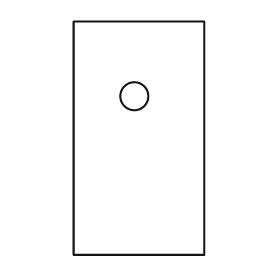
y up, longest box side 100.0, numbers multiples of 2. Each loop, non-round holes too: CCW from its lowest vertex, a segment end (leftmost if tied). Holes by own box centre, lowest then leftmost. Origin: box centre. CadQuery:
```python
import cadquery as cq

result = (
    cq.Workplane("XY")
    .moveTo(-28.0, -50.0)
    .lineTo(28.0, -50.0)
    .lineTo(28.0, 50.0)
    .lineTo(-28.0, 50.0)
    .close()
    .moveTo(-2.0, 18.0)
    .circle(6.0)
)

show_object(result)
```